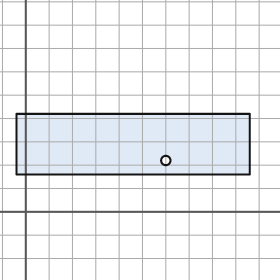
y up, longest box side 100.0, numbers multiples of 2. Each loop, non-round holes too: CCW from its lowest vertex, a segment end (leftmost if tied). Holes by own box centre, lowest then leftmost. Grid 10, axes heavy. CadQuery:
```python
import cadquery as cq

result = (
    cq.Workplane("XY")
    .moveTo(-4.0, 16.0)
    .lineTo(96.0, 16.0)
    .lineTo(96.0, 42.0)
    .lineTo(-4.0, 42.0)
    .close()
    .moveTo(60.0, 22.0)
    .circle(2.0)
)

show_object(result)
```